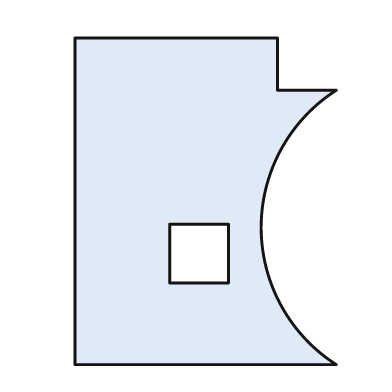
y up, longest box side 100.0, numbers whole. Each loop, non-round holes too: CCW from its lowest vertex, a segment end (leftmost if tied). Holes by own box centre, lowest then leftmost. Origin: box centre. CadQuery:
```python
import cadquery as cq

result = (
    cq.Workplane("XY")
    .moveTo(-40.0, -50.0)
    .lineTo(40.0, -50.0)
    .threePointArc((17.0, -8.0), (40.0, 34.0))
    .lineTo(22.0, 34.0)
    .lineTo(22.0, 50.0)
    .lineTo(-40.0, 50.0)
    .close()
    .moveTo(-11.0, -25.0)
    .lineTo(7.0, -25.0)
    .lineTo(7.0, -7.0)
    .lineTo(-11.0, -7.0)
    .close()
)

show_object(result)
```